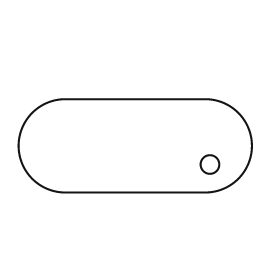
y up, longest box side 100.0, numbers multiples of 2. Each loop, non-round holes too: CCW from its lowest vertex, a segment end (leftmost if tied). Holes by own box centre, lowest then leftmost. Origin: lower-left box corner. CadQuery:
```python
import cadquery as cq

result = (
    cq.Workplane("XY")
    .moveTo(20.0, 0.0)
    .lineTo(80.0, 0.0)
    .threePointArc((100.0, 20.0), (80.0, 40.0))
    .lineTo(20.0, 40.0)
    .threePointArc((0.0, 20.0), (20.0, 0.0))
    .close()
    .moveTo(82.0, 12.0)
    .circle(4.0)
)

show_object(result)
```